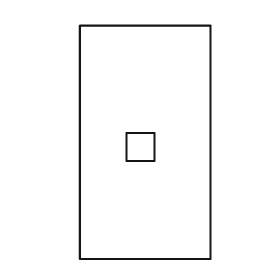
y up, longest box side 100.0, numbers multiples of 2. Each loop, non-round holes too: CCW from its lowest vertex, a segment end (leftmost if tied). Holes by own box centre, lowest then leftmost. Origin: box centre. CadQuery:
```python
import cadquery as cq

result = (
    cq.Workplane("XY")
    .moveTo(-28.0, -50.0)
    .lineTo(28.0, -50.0)
    .lineTo(28.0, 50.0)
    .lineTo(-28.0, 50.0)
    .close()
    .moveTo(-8.0, -8.0)
    .lineTo(4.0, -8.0)
    .lineTo(4.0, 4.0)
    .lineTo(-8.0, 4.0)
    .close()
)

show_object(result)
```